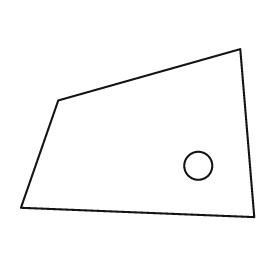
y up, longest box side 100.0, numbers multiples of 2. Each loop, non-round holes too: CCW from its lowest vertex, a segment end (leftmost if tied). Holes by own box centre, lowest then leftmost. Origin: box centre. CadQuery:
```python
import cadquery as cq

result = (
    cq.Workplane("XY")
    .moveTo(50.0, -36.0)
    .lineTo(44.0, 36.0)
    .lineTo(-34.0, 14.0)
    .lineTo(-50.0, -32.0)
    .close()
    .moveTo(26.0, -14.0)
    .circle(6.0)
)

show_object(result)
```